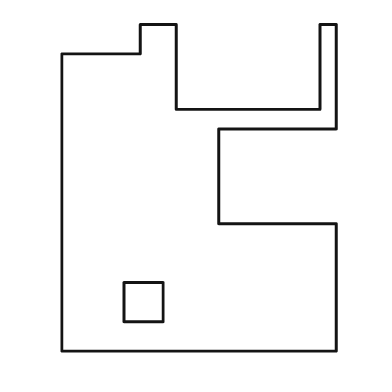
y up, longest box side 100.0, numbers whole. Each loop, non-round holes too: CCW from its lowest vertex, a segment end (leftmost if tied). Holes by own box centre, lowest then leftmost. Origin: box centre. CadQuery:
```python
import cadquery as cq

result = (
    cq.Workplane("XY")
    .moveTo(-42.0, -50.0)
    .lineTo(42.0, -50.0)
    .lineTo(42.0, -11.0)
    .lineTo(6.0, -11.0)
    .lineTo(6.0, 18.0)
    .lineTo(42.0, 18.0)
    .lineTo(42.0, 50.0)
    .lineTo(37.0, 50.0)
    .lineTo(37.0, 24.0)
    .lineTo(-7.0, 24.0)
    .lineTo(-7.0, 50.0)
    .lineTo(-18.0, 50.0)
    .lineTo(-18.0, 41.0)
    .lineTo(-42.0, 41.0)
    .close()
    .moveTo(-23.0, -41.0)
    .lineTo(-11.0, -41.0)
    .lineTo(-11.0, -29.0)
    .lineTo(-23.0, -29.0)
    .close()
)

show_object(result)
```